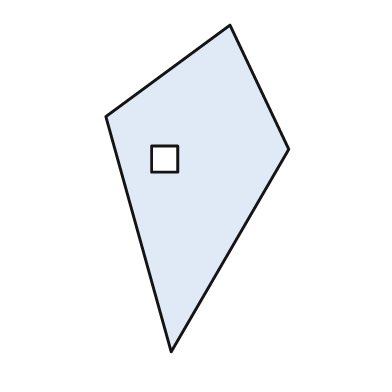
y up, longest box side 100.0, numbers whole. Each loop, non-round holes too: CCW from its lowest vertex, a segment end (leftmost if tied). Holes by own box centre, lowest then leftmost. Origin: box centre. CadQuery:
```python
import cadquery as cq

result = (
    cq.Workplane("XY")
    .moveTo(-8.0, -50.0)
    .lineTo(28.0, 12.0)
    .lineTo(10.0, 50.0)
    .lineTo(-28.0, 22.0)
    .close()
    .moveTo(-14.0, 5.0)
    .lineTo(-6.0, 5.0)
    .lineTo(-6.0, 13.0)
    .lineTo(-14.0, 13.0)
    .close()
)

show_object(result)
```